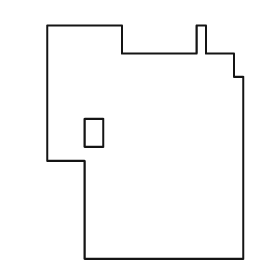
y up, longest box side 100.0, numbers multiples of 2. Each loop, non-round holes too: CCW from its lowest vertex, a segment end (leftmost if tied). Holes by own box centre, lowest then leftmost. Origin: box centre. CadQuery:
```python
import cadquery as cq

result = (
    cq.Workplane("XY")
    .moveTo(-26.0, -50.0)
    .lineTo(42.0, -50.0)
    .lineTo(42.0, 28.0)
    .lineTo(38.0, 28.0)
    .lineTo(38.0, 38.0)
    .lineTo(26.0, 38.0)
    .lineTo(26.0, 50.0)
    .lineTo(22.0, 50.0)
    .lineTo(22.0, 38.0)
    .lineTo(-10.0, 38.0)
    .lineTo(-10.0, 50.0)
    .lineTo(-42.0, 50.0)
    .lineTo(-42.0, -8.0)
    .lineTo(-26.0, -8.0)
    .close()
    .moveTo(-26.0, -2.0)
    .lineTo(-18.0, -2.0)
    .lineTo(-18.0, 10.0)
    .lineTo(-26.0, 10.0)
    .close()
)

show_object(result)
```